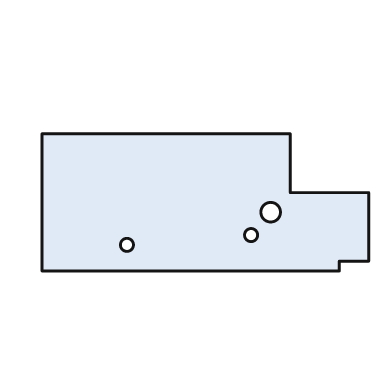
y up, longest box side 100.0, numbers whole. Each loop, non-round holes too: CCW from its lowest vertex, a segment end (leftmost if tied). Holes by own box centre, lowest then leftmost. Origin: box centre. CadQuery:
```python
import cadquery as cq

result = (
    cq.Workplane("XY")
    .moveTo(-50.0, -21.0)
    .lineTo(41.0, -21.0)
    .lineTo(41.0, -18.0)
    .lineTo(50.0, -18.0)
    .lineTo(50.0, 3.0)
    .lineTo(26.0, 3.0)
    .lineTo(26.0, 21.0)
    .lineTo(-50.0, 21.0)
    .close()
    .moveTo(-24.0, -13.0)
    .circle(2.0)
    .moveTo(14.0, -10.0)
    .circle(2.0)
    .moveTo(20.0, -3.0)
    .circle(3.0)
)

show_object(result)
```